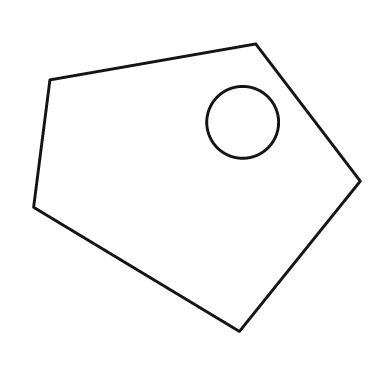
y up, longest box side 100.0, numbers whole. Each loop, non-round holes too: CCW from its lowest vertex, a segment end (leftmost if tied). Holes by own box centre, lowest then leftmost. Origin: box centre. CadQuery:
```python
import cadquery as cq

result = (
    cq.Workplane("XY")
    .moveTo(13.0, -44.0)
    .lineTo(50.0, 2.0)
    .lineTo(18.0, 44.0)
    .lineTo(-45.0, 33.0)
    .lineTo(-50.0, -6.0)
    .close()
    .moveTo(14.0, 20.0)
    .circle(11.0)
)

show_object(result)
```